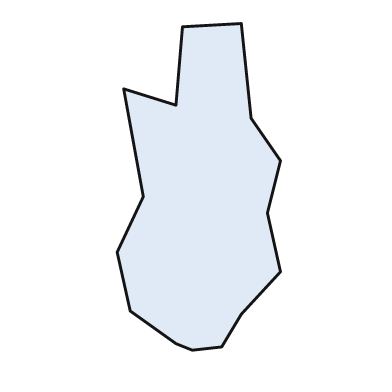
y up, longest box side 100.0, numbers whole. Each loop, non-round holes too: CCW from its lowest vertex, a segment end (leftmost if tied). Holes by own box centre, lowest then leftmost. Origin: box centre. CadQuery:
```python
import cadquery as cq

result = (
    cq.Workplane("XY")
    .moveTo(-2.0, -50.0)
    .lineTo(7.0, -49.0)
    .lineTo(13.0, -39.0)
    .lineTo(25.0, -26.0)
    .lineTo(21.0, -8.0)
    .lineTo(25.0, 8.0)
    .lineTo(16.0, 21.0)
    .lineTo(13.0, 50.0)
    .lineTo(-5.0, 49.0)
    .lineTo(-7.0, 25.0)
    .lineTo(-23.0, 30.0)
    .lineTo(-17.0, -3.0)
    .lineTo(-25.0, -20.0)
    .lineTo(-21.0, -38.0)
    .lineTo(-7.0, -48.0)
    .close()
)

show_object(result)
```